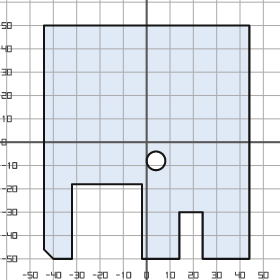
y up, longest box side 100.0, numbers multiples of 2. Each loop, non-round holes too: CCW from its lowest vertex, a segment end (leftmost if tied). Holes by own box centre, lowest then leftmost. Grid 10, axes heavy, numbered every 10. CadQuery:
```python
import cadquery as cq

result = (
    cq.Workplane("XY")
    .moveTo(-40.0, -50.0)
    .lineTo(-32.0, -50.0)
    .lineTo(-32.0, -18.0)
    .lineTo(-2.0, -18.0)
    .lineTo(-2.0, -50.0)
    .lineTo(14.0, -50.0)
    .lineTo(14.0, -30.0)
    .lineTo(24.0, -30.0)
    .lineTo(24.0, -50.0)
    .lineTo(44.0, -50.0)
    .lineTo(44.0, 50.0)
    .lineTo(-44.0, 50.0)
    .lineTo(-44.0, -46.0)
    .close()
    .moveTo(4.0, -8.0)
    .circle(4.0)
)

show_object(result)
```